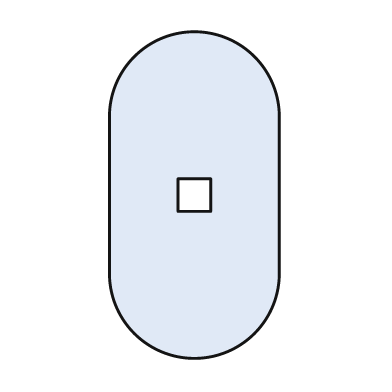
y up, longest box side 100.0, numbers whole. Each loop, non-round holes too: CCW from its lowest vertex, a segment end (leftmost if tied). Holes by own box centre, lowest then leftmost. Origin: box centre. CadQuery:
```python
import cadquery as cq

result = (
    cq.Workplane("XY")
    .moveTo(-26.0, -24.0)
    .threePointArc((0.0, -50.0), (26.0, -24.0))
    .lineTo(26.0, 24.0)
    .threePointArc((0.0, 50.0), (-26.0, 24.0))
    .close()
    .moveTo(-5.0, -5.0)
    .lineTo(5.0, -5.0)
    .lineTo(5.0, 5.0)
    .lineTo(-5.0, 5.0)
    .close()
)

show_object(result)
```